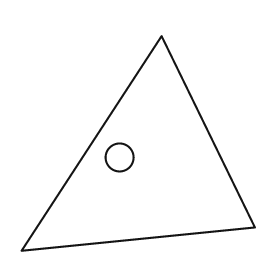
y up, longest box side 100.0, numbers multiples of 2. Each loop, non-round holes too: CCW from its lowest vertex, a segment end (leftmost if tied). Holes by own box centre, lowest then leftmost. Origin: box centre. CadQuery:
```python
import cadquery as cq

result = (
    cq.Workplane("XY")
    .moveTo(-50.0, -46.0)
    .lineTo(50.0, -36.0)
    .lineTo(10.0, 46.0)
    .close()
    .moveTo(-8.0, -6.0)
    .circle(6.0)
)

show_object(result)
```